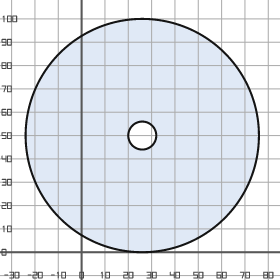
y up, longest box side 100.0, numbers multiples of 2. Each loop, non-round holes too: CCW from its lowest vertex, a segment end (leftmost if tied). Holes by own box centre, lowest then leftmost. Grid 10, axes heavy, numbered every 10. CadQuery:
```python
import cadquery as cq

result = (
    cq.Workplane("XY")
    .moveTo(26.0, 50.0)
    .circle(50.0)
    .moveTo(26.0, 50.0)
    .circle(6.0)
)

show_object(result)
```